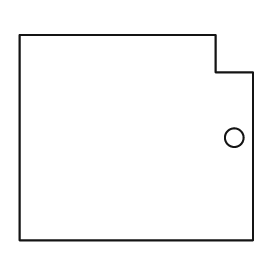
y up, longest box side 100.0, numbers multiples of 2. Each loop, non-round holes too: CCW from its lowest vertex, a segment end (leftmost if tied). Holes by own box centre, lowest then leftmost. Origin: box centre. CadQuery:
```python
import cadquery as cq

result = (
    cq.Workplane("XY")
    .moveTo(-50.0, -44.0)
    .lineTo(50.0, -44.0)
    .lineTo(50.0, 28.0)
    .lineTo(34.0, 28.0)
    .lineTo(34.0, 44.0)
    .lineTo(-50.0, 44.0)
    .close()
    .moveTo(42.0, 0.0)
    .circle(4.0)
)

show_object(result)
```